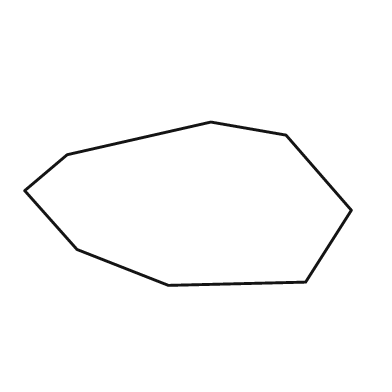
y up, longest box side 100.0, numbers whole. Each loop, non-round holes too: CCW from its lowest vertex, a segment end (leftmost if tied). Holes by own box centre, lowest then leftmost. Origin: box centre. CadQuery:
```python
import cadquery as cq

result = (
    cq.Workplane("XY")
    .moveTo(-6.0, -25.0)
    .lineTo(36.0, -24.0)
    .lineTo(50.0, -2.0)
    .lineTo(30.0, 21.0)
    .lineTo(7.0, 25.0)
    .lineTo(-37.0, 15.0)
    .lineTo(-50.0, 4.0)
    .lineTo(-34.0, -14.0)
    .close()
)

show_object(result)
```